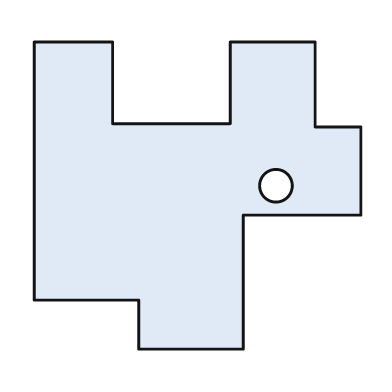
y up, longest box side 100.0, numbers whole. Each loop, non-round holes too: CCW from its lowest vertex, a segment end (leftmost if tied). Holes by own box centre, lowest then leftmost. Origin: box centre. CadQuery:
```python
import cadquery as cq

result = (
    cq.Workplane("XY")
    .moveTo(-18.0, -47.0)
    .lineTo(14.0, -47.0)
    .lineTo(14.0, -6.0)
    .lineTo(50.0, -6.0)
    .lineTo(50.0, 21.0)
    .lineTo(36.0, 21.0)
    .lineTo(36.0, 47.0)
    .lineTo(10.0, 47.0)
    .lineTo(10.0, 22.0)
    .lineTo(-26.0, 22.0)
    .lineTo(-26.0, 47.0)
    .lineTo(-50.0, 47.0)
    .lineTo(-50.0, -32.0)
    .lineTo(-18.0, -32.0)
    .close()
    .moveTo(24.0, 3.0)
    .circle(5.0)
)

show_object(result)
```